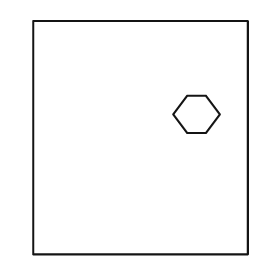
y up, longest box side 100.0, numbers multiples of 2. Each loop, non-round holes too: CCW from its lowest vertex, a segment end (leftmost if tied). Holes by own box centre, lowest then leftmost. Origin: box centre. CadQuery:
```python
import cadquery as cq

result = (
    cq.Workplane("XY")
    .moveTo(-46.0, -50.0)
    .lineTo(46.0, -50.0)
    .lineTo(46.0, 50.0)
    .lineTo(-46.0, 50.0)
    .close()
    .moveTo(20.0, 2.0)
    .lineTo(28.0, 2.0)
    .lineTo(34.0, 10.0)
    .lineTo(28.0, 18.0)
    .lineTo(20.0, 18.0)
    .lineTo(14.0, 10.0)
    .close()
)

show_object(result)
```